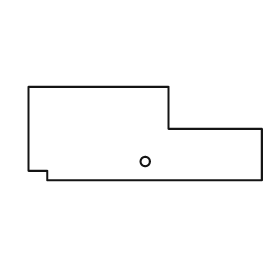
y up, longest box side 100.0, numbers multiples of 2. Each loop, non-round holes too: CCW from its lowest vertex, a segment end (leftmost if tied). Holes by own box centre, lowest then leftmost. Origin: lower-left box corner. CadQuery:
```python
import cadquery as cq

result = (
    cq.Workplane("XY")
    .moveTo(8.0, 0.0)
    .lineTo(100.0, 0.0)
    .lineTo(100.0, 22.0)
    .lineTo(60.0, 22.0)
    .lineTo(60.0, 40.0)
    .lineTo(0.0, 40.0)
    .lineTo(0.0, 4.0)
    .lineTo(8.0, 4.0)
    .close()
    .moveTo(50.0, 8.0)
    .circle(2.0)
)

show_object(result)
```